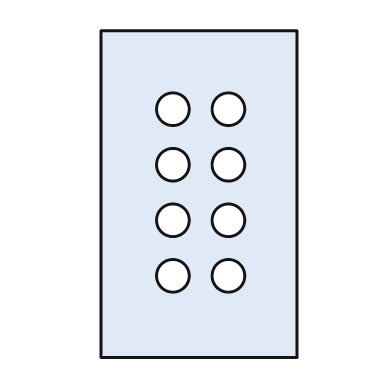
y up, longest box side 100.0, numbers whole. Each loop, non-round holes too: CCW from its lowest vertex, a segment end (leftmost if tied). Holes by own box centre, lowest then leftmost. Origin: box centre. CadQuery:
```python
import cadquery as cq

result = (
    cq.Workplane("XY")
    .moveTo(-30.0, -50.0)
    .lineTo(30.0, -50.0)
    .lineTo(30.0, 50.0)
    .lineTo(-30.0, 50.0)
    .close()
    .moveTo(-8.0, -25.0)
    .circle(5.0)
    .moveTo(9.0, -25.0)
    .circle(5.0)
    .moveTo(-8.0, -8.0)
    .circle(5.0)
    .moveTo(9.0, -8.0)
    .circle(5.0)
    .moveTo(-8.0, 9.0)
    .circle(5.0)
    .moveTo(9.0, 9.0)
    .circle(5.0)
    .moveTo(-8.0, 26.0)
    .circle(5.0)
    .moveTo(9.0, 26.0)
    .circle(5.0)
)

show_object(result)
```